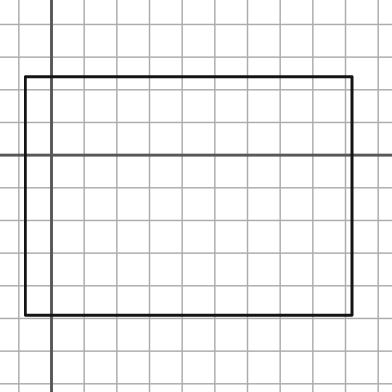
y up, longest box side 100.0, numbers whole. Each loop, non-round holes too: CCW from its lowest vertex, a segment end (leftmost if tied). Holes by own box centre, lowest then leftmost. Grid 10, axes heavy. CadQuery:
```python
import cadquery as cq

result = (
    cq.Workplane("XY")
    .moveTo(-8.0, -49.0)
    .lineTo(92.0, -49.0)
    .lineTo(92.0, 24.0)
    .lineTo(-8.0, 24.0)
    .close()
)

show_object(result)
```